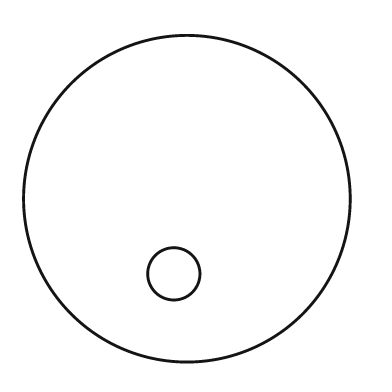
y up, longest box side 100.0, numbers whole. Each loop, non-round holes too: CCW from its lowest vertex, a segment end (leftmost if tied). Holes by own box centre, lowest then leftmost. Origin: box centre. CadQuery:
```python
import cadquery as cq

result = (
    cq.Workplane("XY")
    .moveTo(0.0, 0.0)
    .circle(50.0)
    .moveTo(-4.0, -23.0)
    .circle(8.0)
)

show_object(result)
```